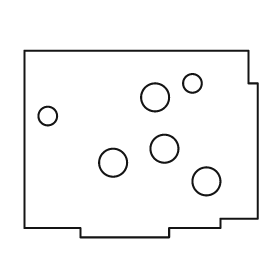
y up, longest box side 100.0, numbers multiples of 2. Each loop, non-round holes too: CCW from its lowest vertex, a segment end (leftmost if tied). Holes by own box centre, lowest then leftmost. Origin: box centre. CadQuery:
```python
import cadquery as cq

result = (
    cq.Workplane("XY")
    .moveTo(-26.0, -40.0)
    .lineTo(12.0, -40.0)
    .lineTo(12.0, -36.0)
    .lineTo(34.0, -36.0)
    .lineTo(34.0, -32.0)
    .lineTo(50.0, -32.0)
    .lineTo(50.0, 26.0)
    .lineTo(46.0, 26.0)
    .lineTo(46.0, 40.0)
    .lineTo(-50.0, 40.0)
    .lineTo(-50.0, -36.0)
    .lineTo(-26.0, -36.0)
    .close()
    .moveTo(28.0, -16.0)
    .circle(6.0)
    .moveTo(-12.0, -8.0)
    .circle(6.0)
    .moveTo(10.0, -2.0)
    .circle(6.0)
    .moveTo(-40.0, 12.0)
    .circle(4.0)
    .moveTo(6.0, 20.0)
    .circle(6.0)
    .moveTo(22.0, 26.0)
    .circle(4.0)
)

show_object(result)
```